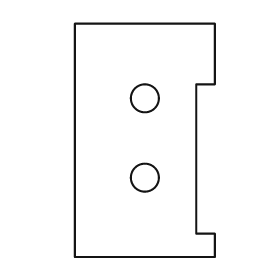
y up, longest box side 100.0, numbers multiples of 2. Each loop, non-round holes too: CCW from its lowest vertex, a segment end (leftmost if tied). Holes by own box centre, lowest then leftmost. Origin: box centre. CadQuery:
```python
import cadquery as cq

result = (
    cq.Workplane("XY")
    .moveTo(-30.0, -50.0)
    .lineTo(30.0, -50.0)
    .lineTo(30.0, -40.0)
    .lineTo(22.0, -40.0)
    .lineTo(22.0, 24.0)
    .lineTo(30.0, 24.0)
    .lineTo(30.0, 50.0)
    .lineTo(-30.0, 50.0)
    .close()
    .moveTo(0.0, -16.0)
    .circle(6.0)
    .moveTo(0.0, 18.0)
    .circle(6.0)
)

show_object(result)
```